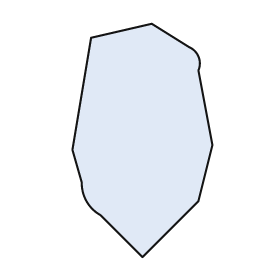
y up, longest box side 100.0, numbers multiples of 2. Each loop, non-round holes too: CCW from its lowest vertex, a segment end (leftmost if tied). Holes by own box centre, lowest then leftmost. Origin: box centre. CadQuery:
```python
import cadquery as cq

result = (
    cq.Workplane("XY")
    .moveTo(0.0, -50.0)
    .lineTo(24.0, -26.0)
    .lineTo(30.0, -2.0)
    .lineTo(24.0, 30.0)
    .threePointArc((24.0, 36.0), (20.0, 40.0))
    .lineTo(4.0, 50.0)
    .lineTo(-22.0, 44.0)
    .lineTo(-30.0, -4.0)
    .lineTo(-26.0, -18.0)
    .threePointArc((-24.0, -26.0), (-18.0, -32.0))
    .close()
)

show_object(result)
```